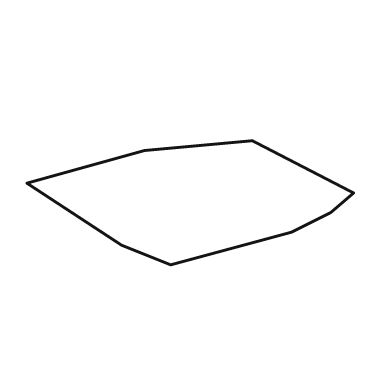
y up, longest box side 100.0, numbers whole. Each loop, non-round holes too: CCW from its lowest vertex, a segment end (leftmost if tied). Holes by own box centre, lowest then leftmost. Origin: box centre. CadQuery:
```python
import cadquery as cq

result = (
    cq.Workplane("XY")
    .moveTo(-6.0, -19.0)
    .lineTo(31.0, -9.0)
    .lineTo(43.0, -3.0)
    .lineTo(50.0, 3.0)
    .lineTo(19.0, 19.0)
    .lineTo(-14.0, 16.0)
    .lineTo(-50.0, 6.0)
    .lineTo(-21.0, -13.0)
    .close()
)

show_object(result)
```